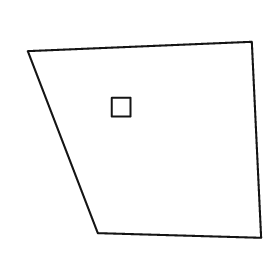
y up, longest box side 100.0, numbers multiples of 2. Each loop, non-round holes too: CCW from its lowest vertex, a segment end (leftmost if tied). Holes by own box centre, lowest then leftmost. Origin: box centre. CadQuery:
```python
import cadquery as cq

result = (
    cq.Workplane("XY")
    .moveTo(50.0, -42.0)
    .lineTo(46.0, 42.0)
    .lineTo(-50.0, 38.0)
    .lineTo(-20.0, -40.0)
    .close()
    .moveTo(-14.0, 10.0)
    .lineTo(-6.0, 10.0)
    .lineTo(-6.0, 18.0)
    .lineTo(-14.0, 18.0)
    .close()
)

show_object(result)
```